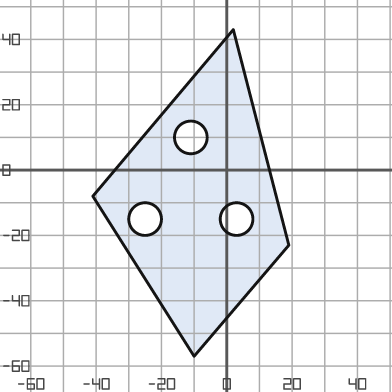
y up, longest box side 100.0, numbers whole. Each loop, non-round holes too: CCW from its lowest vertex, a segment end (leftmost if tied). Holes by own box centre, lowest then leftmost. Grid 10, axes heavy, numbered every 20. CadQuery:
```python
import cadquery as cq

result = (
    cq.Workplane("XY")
    .moveTo(-10.0, -57.0)
    .lineTo(19.0, -23.0)
    .lineTo(2.0, 43.0)
    .lineTo(-41.0, -8.0)
    .close()
    .moveTo(-25.0, -15.0)
    .circle(5.0)
    .moveTo(3.0, -15.0)
    .circle(5.0)
    .moveTo(-11.0, 10.0)
    .circle(5.0)
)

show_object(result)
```